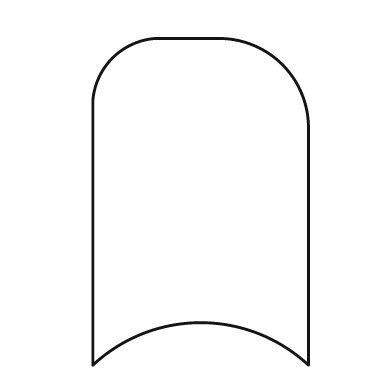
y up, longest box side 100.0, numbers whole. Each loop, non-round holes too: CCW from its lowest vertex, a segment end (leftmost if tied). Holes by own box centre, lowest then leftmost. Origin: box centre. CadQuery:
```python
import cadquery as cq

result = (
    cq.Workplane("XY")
    .moveTo(-33.0, -50.0)
    .threePointArc((0.0, -37.0), (33.0, -50.0))
    .lineTo(33.0, 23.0)
    .threePointArc((25.0, 42.0), (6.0, 50.0))
    .lineTo(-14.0, 50.0)
    .threePointArc((-27.0, 44.0), (-33.0, 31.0))
    .close()
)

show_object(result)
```